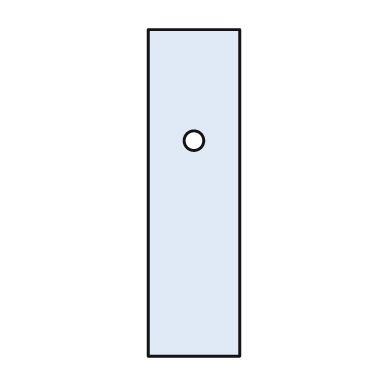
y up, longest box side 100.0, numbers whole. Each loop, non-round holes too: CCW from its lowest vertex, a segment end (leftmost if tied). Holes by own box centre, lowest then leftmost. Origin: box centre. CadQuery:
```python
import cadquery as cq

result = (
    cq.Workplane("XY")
    .moveTo(-14.0, -50.0)
    .lineTo(14.0, -50.0)
    .lineTo(14.0, 50.0)
    .lineTo(-14.0, 50.0)
    .close()
    .moveTo(0.0, 16.0)
    .circle(3.0)
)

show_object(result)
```